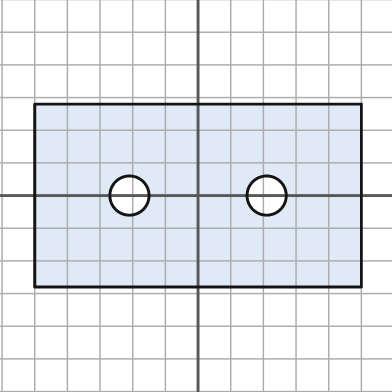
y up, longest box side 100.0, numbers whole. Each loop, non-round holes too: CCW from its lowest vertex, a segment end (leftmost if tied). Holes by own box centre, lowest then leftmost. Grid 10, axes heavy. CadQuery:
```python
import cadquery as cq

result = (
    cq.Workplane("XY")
    .moveTo(-50.0, -28.0)
    .lineTo(50.0, -28.0)
    .lineTo(50.0, 28.0)
    .lineTo(-50.0, 28.0)
    .close()
    .moveTo(-21.0, 0.0)
    .circle(6.0)
    .moveTo(21.0, 0.0)
    .circle(6.0)
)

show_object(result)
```